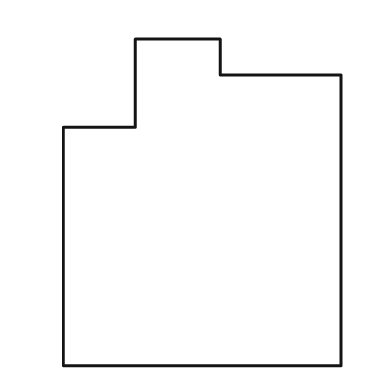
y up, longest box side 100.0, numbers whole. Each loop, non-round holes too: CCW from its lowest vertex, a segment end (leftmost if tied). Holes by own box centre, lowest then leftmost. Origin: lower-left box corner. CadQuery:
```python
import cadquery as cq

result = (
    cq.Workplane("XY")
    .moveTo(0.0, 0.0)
    .lineTo(85.0, 0.0)
    .lineTo(85.0, 89.0)
    .lineTo(48.0, 89.0)
    .lineTo(48.0, 100.0)
    .lineTo(22.0, 100.0)
    .lineTo(22.0, 73.0)
    .lineTo(0.0, 73.0)
    .close()
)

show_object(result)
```